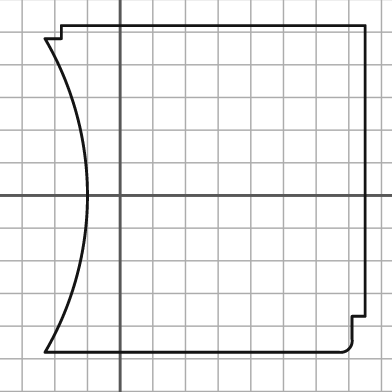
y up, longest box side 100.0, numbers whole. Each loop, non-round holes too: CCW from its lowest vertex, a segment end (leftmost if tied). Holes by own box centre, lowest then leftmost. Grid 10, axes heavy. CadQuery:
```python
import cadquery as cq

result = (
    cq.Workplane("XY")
    .moveTo(-23.0, -48.0)
    .lineTo(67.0, -48.0)
    .threePointArc((70.0, -47.0), (71.0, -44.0))
    .lineTo(71.0, -37.0)
    .lineTo(75.0, -37.0)
    .lineTo(75.0, 52.0)
    .lineTo(-18.0, 52.0)
    .lineTo(-18.0, 48.0)
    .lineTo(-23.0, 48.0)
    .threePointArc((-10.0, 0.0), (-23.0, -48.0))
    .close()
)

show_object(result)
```